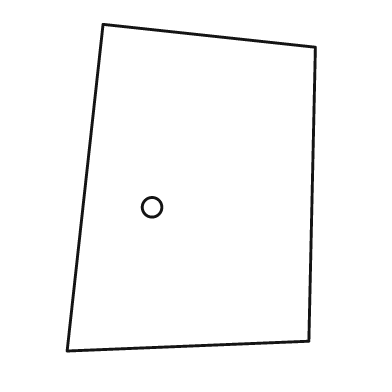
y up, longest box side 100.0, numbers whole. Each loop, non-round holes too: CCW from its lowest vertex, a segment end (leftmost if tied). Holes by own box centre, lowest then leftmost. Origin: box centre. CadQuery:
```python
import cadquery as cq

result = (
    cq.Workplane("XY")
    .moveTo(-38.0, -50.0)
    .lineTo(36.0, -47.0)
    .lineTo(38.0, 43.0)
    .lineTo(-27.0, 50.0)
    .close()
    .moveTo(-12.0, -6.0)
    .circle(3.0)
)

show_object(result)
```